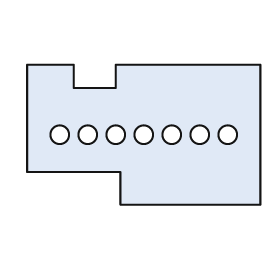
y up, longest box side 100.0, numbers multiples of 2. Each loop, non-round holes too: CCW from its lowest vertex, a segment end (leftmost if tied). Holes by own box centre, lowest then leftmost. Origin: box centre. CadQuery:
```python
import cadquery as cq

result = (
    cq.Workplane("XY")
    .moveTo(-10.0, -30.0)
    .lineTo(50.0, -30.0)
    .lineTo(50.0, 30.0)
    .lineTo(-12.0, 30.0)
    .lineTo(-12.0, 20.0)
    .lineTo(-30.0, 20.0)
    .lineTo(-30.0, 30.0)
    .lineTo(-50.0, 30.0)
    .lineTo(-50.0, -16.0)
    .lineTo(-10.0, -16.0)
    .close()
    .moveTo(-36.0, 0.0)
    .circle(4.0)
    .moveTo(-24.0, 0.0)
    .circle(4.0)
    .moveTo(-12.0, 0.0)
    .circle(4.0)
    .moveTo(0.0, 0.0)
    .circle(4.0)
    .moveTo(12.0, 0.0)
    .circle(4.0)
    .moveTo(24.0, 0.0)
    .circle(4.0)
    .moveTo(36.0, 0.0)
    .circle(4.0)
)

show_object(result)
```